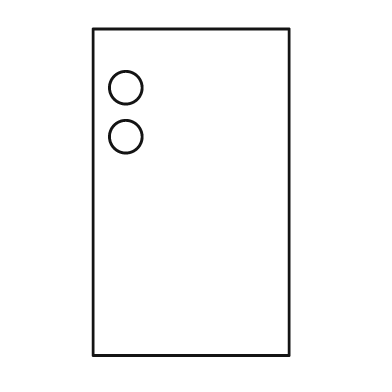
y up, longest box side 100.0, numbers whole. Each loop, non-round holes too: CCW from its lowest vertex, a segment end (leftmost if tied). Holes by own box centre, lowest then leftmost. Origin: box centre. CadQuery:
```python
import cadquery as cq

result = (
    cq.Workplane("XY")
    .moveTo(-30.0, -50.0)
    .lineTo(30.0, -50.0)
    .lineTo(30.0, 50.0)
    .lineTo(-30.0, 50.0)
    .close()
    .moveTo(-20.0, 17.0)
    .circle(5.0)
    .moveTo(-20.0, 32.0)
    .circle(5.0)
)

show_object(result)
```